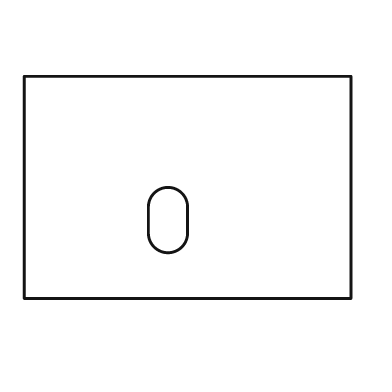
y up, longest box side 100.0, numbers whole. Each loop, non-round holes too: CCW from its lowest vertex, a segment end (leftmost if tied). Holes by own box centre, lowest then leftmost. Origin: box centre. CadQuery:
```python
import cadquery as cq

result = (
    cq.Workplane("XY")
    .moveTo(-50.0, -34.0)
    .lineTo(50.0, -34.0)
    .lineTo(50.0, 34.0)
    .lineTo(-50.0, 34.0)
    .close()
    .moveTo(-12.0, -14.0)
    .threePointArc((-6.0, -20.0), (0.0, -14.0))
    .lineTo(0.0, -6.0)
    .threePointArc((-6.0, 0.0), (-12.0, -6.0))
    .close()
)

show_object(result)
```